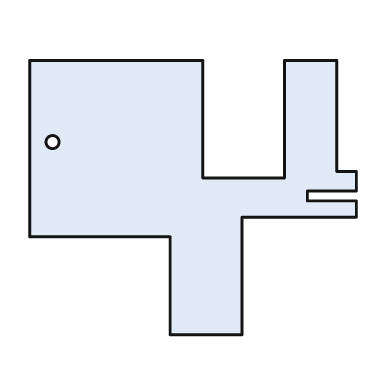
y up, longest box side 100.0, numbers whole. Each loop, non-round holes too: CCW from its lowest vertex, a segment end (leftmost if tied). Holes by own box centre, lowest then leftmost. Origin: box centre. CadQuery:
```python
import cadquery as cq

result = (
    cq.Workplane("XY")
    .moveTo(-7.0, -42.0)
    .lineTo(15.0, -42.0)
    .lineTo(15.0, -6.0)
    .lineTo(50.0, -6.0)
    .lineTo(50.0, -1.0)
    .lineTo(35.0, -1.0)
    .lineTo(35.0, 2.0)
    .lineTo(50.0, 2.0)
    .lineTo(50.0, 8.0)
    .lineTo(44.0, 8.0)
    .lineTo(44.0, 42.0)
    .lineTo(28.0, 42.0)
    .lineTo(28.0, 6.0)
    .lineTo(3.0, 6.0)
    .lineTo(3.0, 42.0)
    .lineTo(-50.0, 42.0)
    .lineTo(-50.0, -12.0)
    .lineTo(-7.0, -12.0)
    .close()
    .moveTo(-43.0, 17.0)
    .circle(2.0)
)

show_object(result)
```